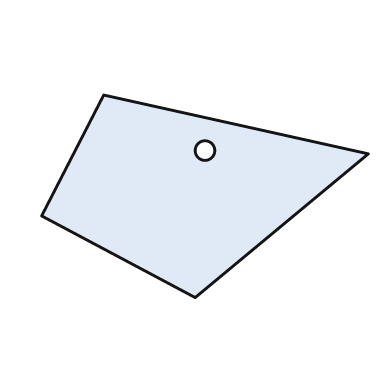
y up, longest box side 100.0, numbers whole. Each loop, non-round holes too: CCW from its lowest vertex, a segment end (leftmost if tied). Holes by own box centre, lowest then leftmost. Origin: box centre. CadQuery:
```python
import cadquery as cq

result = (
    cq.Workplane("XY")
    .moveTo(-3.0, -31.0)
    .lineTo(50.0, 13.0)
    .lineTo(-31.0, 31.0)
    .lineTo(-50.0, -6.0)
    .close()
    .moveTo(0.0, 14.0)
    .circle(3.0)
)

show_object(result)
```